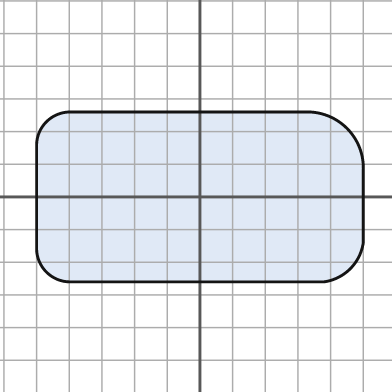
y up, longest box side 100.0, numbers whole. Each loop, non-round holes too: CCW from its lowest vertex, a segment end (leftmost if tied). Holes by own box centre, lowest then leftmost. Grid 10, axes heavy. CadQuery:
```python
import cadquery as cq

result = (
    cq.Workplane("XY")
    .moveTo(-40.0, -26.0)
    .lineTo(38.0, -26.0)
    .threePointArc((46.0, -22.0), (50.0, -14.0))
    .lineTo(50.0, 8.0)
    .threePointArc((45.0, 21.0), (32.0, 26.0))
    .lineTo(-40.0, 26.0)
    .threePointArc((-47.0, 23.0), (-50.0, 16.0))
    .lineTo(-50.0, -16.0)
    .threePointArc((-47.0, -23.0), (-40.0, -26.0))
    .close()
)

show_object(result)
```